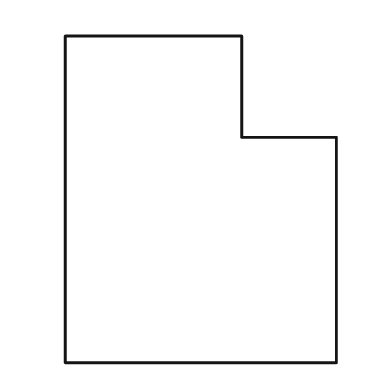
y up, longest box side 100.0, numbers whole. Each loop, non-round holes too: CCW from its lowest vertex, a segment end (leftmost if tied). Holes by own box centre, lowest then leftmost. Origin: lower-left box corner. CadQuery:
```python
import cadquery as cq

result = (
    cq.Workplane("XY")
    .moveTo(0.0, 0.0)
    .lineTo(83.0, 0.0)
    .lineTo(83.0, 69.0)
    .lineTo(54.0, 69.0)
    .lineTo(54.0, 100.0)
    .lineTo(0.0, 100.0)
    .close()
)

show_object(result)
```